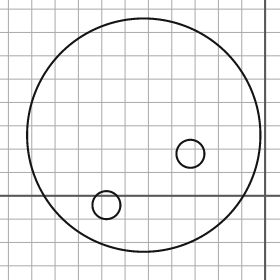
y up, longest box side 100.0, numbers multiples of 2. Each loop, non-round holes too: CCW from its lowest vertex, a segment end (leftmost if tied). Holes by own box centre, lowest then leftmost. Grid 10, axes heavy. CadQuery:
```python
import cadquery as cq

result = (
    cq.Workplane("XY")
    .moveTo(-52.0, 26.0)
    .circle(50.0)
    .moveTo(-68.0, -4.0)
    .circle(6.0)
    .moveTo(-32.0, 18.0)
    .circle(6.0)
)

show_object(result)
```